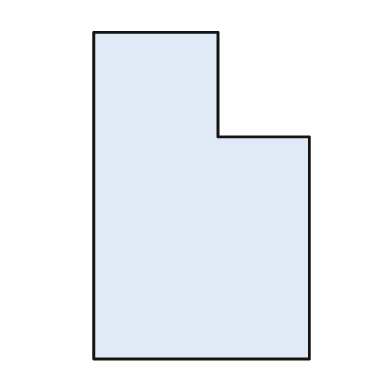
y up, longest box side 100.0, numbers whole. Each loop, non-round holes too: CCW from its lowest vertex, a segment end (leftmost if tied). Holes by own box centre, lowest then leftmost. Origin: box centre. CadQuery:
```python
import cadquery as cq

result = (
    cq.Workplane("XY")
    .moveTo(-33.0, -50.0)
    .lineTo(33.0, -50.0)
    .lineTo(33.0, 18.0)
    .lineTo(5.0, 18.0)
    .lineTo(5.0, 50.0)
    .lineTo(-33.0, 50.0)
    .close()
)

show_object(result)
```